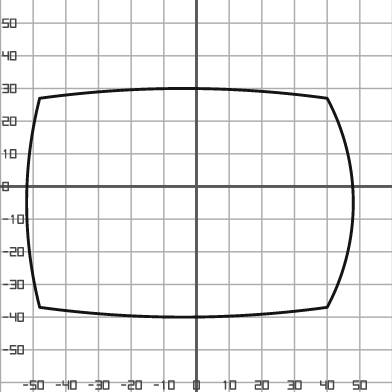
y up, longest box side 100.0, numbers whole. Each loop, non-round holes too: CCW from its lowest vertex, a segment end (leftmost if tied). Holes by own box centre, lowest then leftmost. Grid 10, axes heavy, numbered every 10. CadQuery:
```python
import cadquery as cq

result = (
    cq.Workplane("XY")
    .moveTo(-48.0, -37.0)
    .threePointArc((-4.0, -40.0), (40.0, -37.0))
    .threePointArc((48.0, -5.0), (40.0, 27.0))
    .threePointArc((-4.0, 30.0), (-48.0, 27.0))
    .threePointArc((-52.0, -5.0), (-48.0, -37.0))
    .close()
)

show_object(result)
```